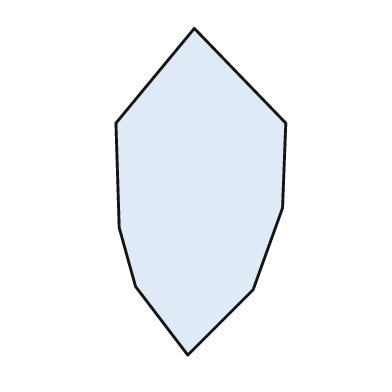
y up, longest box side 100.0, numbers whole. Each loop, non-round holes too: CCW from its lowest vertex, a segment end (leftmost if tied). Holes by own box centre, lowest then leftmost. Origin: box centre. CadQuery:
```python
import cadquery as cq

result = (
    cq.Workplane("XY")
    .moveTo(-4.0, -50.0)
    .lineTo(16.0, -30.0)
    .lineTo(25.0, -5.0)
    .lineTo(26.0, 21.0)
    .lineTo(-2.0, 50.0)
    .lineTo(-26.0, 21.0)
    .lineTo(-25.0, -11.0)
    .lineTo(-20.0, -29.0)
    .close()
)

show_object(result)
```